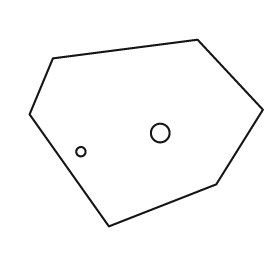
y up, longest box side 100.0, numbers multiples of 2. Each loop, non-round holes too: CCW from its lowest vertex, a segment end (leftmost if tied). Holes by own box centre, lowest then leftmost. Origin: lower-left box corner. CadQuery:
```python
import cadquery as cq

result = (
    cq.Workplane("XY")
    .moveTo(34.0, 0.0)
    .lineTo(80.0, 18.0)
    .lineTo(100.0, 50.0)
    .lineTo(72.0, 80.0)
    .lineTo(10.0, 72.0)
    .lineTo(0.0, 48.0)
    .close()
    .moveTo(22.0, 32.0)
    .circle(2.0)
    .moveTo(56.0, 40.0)
    .circle(4.0)
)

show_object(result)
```